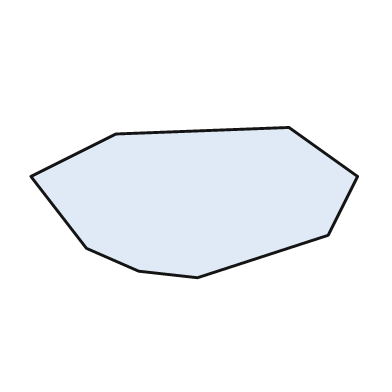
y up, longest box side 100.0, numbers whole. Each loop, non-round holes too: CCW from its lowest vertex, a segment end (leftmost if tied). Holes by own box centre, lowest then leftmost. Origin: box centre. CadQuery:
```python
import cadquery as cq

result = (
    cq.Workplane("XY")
    .moveTo(1.0, -23.0)
    .lineTo(41.0, -10.0)
    .lineTo(50.0, 8.0)
    .lineTo(29.0, 23.0)
    .lineTo(-24.0, 21.0)
    .lineTo(-50.0, 8.0)
    .lineTo(-33.0, -14.0)
    .lineTo(-17.0, -21.0)
    .close()
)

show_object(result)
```